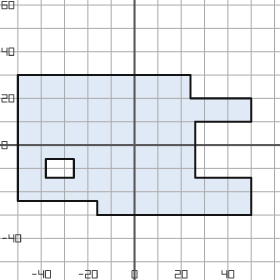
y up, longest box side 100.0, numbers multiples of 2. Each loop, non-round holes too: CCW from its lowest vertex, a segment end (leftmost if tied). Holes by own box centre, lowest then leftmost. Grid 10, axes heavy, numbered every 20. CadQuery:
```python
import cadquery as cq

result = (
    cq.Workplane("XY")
    .moveTo(-16.0, -30.0)
    .lineTo(50.0, -30.0)
    .lineTo(50.0, -14.0)
    .lineTo(26.0, -14.0)
    .lineTo(26.0, 10.0)
    .lineTo(50.0, 10.0)
    .lineTo(50.0, 20.0)
    .lineTo(24.0, 20.0)
    .lineTo(24.0, 30.0)
    .lineTo(-50.0, 30.0)
    .lineTo(-50.0, -24.0)
    .lineTo(-16.0, -24.0)
    .close()
    .moveTo(-38.0, -14.0)
    .lineTo(-26.0, -14.0)
    .lineTo(-26.0, -6.0)
    .lineTo(-38.0, -6.0)
    .close()
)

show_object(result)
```